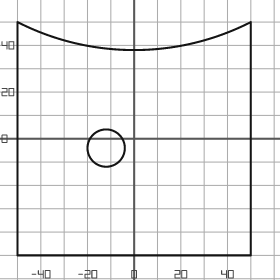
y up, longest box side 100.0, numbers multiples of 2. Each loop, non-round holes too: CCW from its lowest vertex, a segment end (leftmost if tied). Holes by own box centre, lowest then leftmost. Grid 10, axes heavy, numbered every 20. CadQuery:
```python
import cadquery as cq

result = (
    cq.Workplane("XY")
    .moveTo(-50.0, -50.0)
    .lineTo(50.0, -50.0)
    .lineTo(50.0, 50.0)
    .threePointArc((0.0, 38.0), (-50.0, 50.0))
    .close()
    .moveTo(-12.0, -4.0)
    .circle(8.0)
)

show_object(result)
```